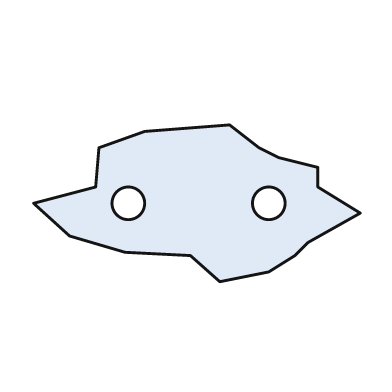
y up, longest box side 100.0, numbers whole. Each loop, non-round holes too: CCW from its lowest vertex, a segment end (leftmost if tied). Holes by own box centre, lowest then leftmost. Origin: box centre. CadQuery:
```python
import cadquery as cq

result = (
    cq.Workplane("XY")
    .moveTo(7.0, -24.0)
    .lineTo(22.0, -21.0)
    .lineTo(30.0, -16.0)
    .lineTo(34.0, -12.0)
    .lineTo(50.0, -3.0)
    .lineTo(37.0, 5.0)
    .lineTo(37.0, 11.0)
    .lineTo(25.0, 14.0)
    .lineTo(19.0, 17.0)
    .lineTo(10.0, 24.0)
    .lineTo(-16.0, 22.0)
    .lineTo(-30.0, 17.0)
    .lineTo(-31.0, 5.0)
    .lineTo(-50.0, 0.0)
    .lineTo(-39.0, -10.0)
    .lineTo(-22.0, -15.0)
    .lineTo(-2.0, -16.0)
    .close()
    .moveTo(-21.0, 0.0)
    .circle(5.0)
    .moveTo(22.0, 0.0)
    .circle(5.0)
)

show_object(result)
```